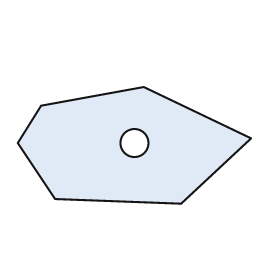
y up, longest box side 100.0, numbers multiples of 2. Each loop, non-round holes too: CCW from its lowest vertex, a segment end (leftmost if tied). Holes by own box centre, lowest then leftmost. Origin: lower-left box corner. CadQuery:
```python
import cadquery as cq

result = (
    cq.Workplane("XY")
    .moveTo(70.0, 0.0)
    .lineTo(100.0, 28.0)
    .lineTo(54.0, 50.0)
    .lineTo(10.0, 42.0)
    .lineTo(0.0, 26.0)
    .lineTo(16.0, 2.0)
    .close()
    .moveTo(50.0, 26.0)
    .circle(6.0)
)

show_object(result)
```